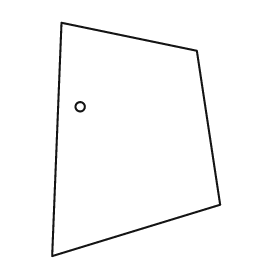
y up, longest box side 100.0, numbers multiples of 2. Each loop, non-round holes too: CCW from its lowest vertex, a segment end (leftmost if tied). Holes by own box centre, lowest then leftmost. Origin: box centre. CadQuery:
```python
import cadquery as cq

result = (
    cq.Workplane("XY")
    .moveTo(-36.0, -50.0)
    .lineTo(36.0, -28.0)
    .lineTo(26.0, 38.0)
    .lineTo(-32.0, 50.0)
    .close()
    .moveTo(-24.0, 14.0)
    .circle(2.0)
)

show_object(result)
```